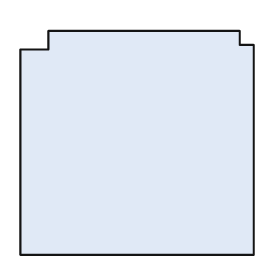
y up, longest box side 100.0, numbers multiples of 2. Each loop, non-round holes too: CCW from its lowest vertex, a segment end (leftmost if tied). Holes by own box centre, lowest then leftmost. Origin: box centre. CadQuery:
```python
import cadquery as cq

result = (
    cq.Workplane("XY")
    .moveTo(-50.0, -48.0)
    .lineTo(50.0, -48.0)
    .lineTo(50.0, 42.0)
    .lineTo(44.0, 42.0)
    .lineTo(44.0, 48.0)
    .lineTo(-38.0, 48.0)
    .lineTo(-38.0, 40.0)
    .lineTo(-50.0, 40.0)
    .close()
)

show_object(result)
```